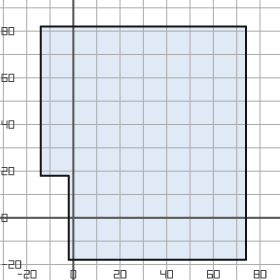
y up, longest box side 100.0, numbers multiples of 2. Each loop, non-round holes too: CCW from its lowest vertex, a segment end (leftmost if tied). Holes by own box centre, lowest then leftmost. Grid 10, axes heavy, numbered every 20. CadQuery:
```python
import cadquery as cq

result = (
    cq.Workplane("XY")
    .moveTo(-2.0, -18.0)
    .lineTo(74.0, -18.0)
    .lineTo(74.0, 82.0)
    .lineTo(-14.0, 82.0)
    .lineTo(-14.0, 18.0)
    .lineTo(-2.0, 18.0)
    .close()
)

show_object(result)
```